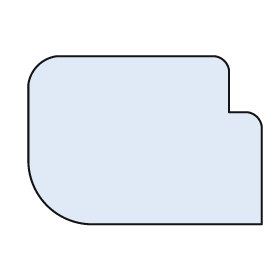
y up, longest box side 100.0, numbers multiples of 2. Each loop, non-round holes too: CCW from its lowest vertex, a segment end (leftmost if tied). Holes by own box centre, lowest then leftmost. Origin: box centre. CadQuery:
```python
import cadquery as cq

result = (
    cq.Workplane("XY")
    .moveTo(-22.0, -36.0)
    .lineTo(50.0, -36.0)
    .lineTo(50.0, 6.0)
    .threePointArc((48.0, 10.0), (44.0, 12.0))
    .lineTo(36.0, 12.0)
    .lineTo(36.0, 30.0)
    .threePointArc((34.0, 34.0), (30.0, 36.0))
    .lineTo(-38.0, 36.0)
    .threePointArc((-46.0, 32.0), (-50.0, 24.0))
    .lineTo(-50.0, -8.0)
    .threePointArc((-42.0, -28.0), (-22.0, -36.0))
    .close()
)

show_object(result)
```